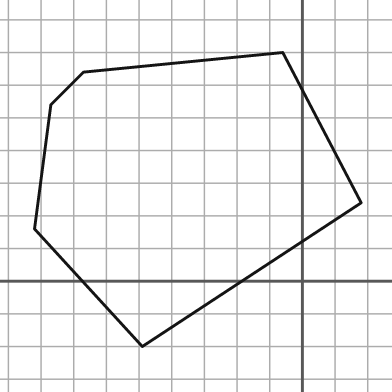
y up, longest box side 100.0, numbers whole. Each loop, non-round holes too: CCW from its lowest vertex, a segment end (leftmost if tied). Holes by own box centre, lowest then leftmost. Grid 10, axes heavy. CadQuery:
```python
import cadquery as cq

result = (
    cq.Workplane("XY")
    .moveTo(-49.0, -20.0)
    .lineTo(18.0, 24.0)
    .lineTo(-6.0, 70.0)
    .lineTo(-67.0, 64.0)
    .lineTo(-77.0, 54.0)
    .lineTo(-82.0, 16.0)
    .close()
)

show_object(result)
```